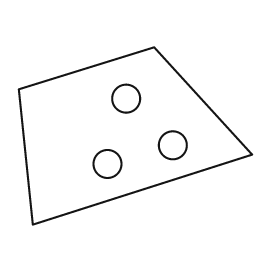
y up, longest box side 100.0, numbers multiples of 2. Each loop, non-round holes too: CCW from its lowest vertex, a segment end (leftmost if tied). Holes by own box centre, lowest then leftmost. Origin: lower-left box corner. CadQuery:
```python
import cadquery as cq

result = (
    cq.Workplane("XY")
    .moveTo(6.0, 0.0)
    .lineTo(100.0, 30.0)
    .lineTo(58.0, 76.0)
    .lineTo(0.0, 58.0)
    .close()
    .moveTo(38.0, 26.0)
    .circle(6.0)
    .moveTo(66.0, 34.0)
    .circle(6.0)
    .moveTo(46.0, 54.0)
    .circle(6.0)
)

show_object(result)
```